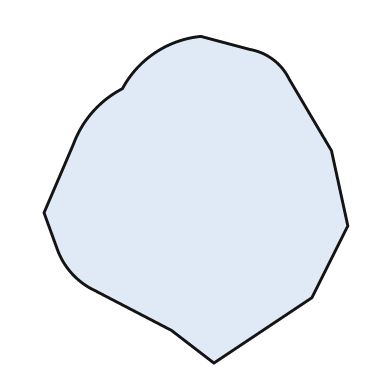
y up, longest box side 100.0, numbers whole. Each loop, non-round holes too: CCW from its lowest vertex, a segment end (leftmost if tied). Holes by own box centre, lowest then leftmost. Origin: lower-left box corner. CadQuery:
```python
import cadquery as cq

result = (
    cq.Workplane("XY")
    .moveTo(52.0, 0.0)
    .lineTo(82.0, 20.0)
    .lineTo(93.0, 42.0)
    .lineTo(88.0, 65.0)
    .lineTo(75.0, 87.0)
    .threePointArc((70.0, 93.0), (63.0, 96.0))
    .lineTo(48.0, 100.0)
    .threePointArc((34.0, 95.0), (24.0, 84.0))
    .threePointArc((15.0, 77.0), (9.0, 67.0))
    .lineTo(0.0, 46.0)
    .lineTo(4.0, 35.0)
    .threePointArc((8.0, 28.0), (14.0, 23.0))
    .lineTo(39.0, 10.0)
    .close()
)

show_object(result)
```